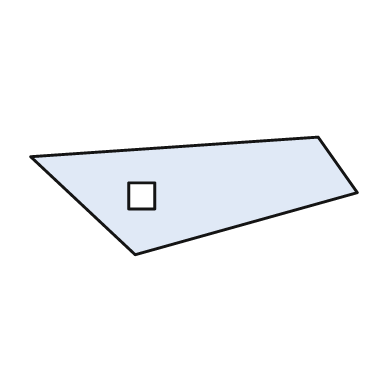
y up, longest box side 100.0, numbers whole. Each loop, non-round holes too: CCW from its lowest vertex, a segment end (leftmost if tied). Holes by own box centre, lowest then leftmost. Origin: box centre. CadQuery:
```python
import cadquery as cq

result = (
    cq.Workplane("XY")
    .moveTo(-18.0, -18.0)
    .lineTo(50.0, 1.0)
    .lineTo(38.0, 18.0)
    .lineTo(-50.0, 12.0)
    .close()
    .moveTo(-20.0, -4.0)
    .lineTo(-12.0, -4.0)
    .lineTo(-12.0, 4.0)
    .lineTo(-20.0, 4.0)
    .close()
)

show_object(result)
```